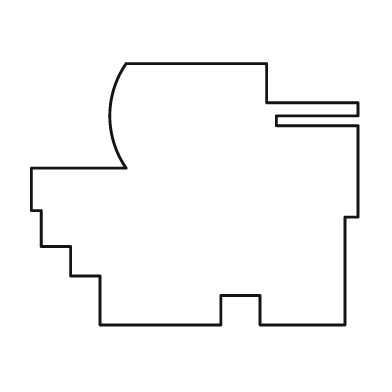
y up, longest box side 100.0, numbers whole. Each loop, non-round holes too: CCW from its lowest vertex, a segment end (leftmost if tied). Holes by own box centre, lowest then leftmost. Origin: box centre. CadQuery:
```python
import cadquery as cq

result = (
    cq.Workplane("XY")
    .moveTo(-29.0, -40.0)
    .lineTo(8.0, -40.0)
    .lineTo(8.0, -31.0)
    .lineTo(20.0, -31.0)
    .lineTo(20.0, -40.0)
    .lineTo(46.0, -40.0)
    .lineTo(46.0, -7.0)
    .lineTo(50.0, -7.0)
    .lineTo(50.0, 21.0)
    .lineTo(25.0, 21.0)
    .lineTo(25.0, 24.0)
    .lineTo(50.0, 24.0)
    .lineTo(50.0, 28.0)
    .lineTo(22.0, 28.0)
    .lineTo(22.0, 40.0)
    .lineTo(-21.0, 40.0)
    .threePointArc((-26.0, 24.0), (-21.0, 8.0))
    .lineTo(-50.0, 8.0)
    .lineTo(-50.0, -5.0)
    .lineTo(-47.0, -5.0)
    .lineTo(-47.0, -16.0)
    .lineTo(-38.0, -16.0)
    .lineTo(-38.0, -25.0)
    .lineTo(-29.0, -25.0)
    .close()
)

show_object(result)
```